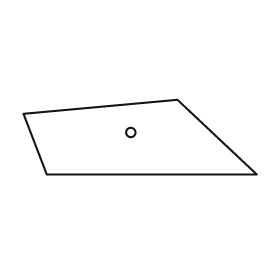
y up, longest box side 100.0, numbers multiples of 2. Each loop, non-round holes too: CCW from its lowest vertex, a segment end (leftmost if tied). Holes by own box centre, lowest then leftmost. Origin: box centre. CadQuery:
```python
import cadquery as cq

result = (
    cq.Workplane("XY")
    .moveTo(-40.0, -16.0)
    .lineTo(50.0, -16.0)
    .lineTo(16.0, 16.0)
    .lineTo(-50.0, 10.0)
    .close()
    .moveTo(-4.0, 2.0)
    .circle(2.0)
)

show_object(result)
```